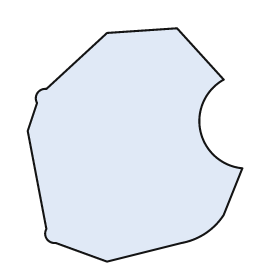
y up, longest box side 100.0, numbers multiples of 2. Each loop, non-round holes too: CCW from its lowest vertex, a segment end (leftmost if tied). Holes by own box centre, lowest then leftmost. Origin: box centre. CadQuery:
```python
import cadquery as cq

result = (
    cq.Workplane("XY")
    .moveTo(-12.0, -50.0)
    .lineTo(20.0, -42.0)
    .threePointArc((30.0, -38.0), (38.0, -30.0))
    .lineTo(46.0, -10.0)
    .threePointArc((28.0, 6.0), (38.0, 28.0))
    .lineTo(18.0, 50.0)
    .lineTo(-12.0, 48.0)
    .lineTo(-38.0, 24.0)
    .threePointArc((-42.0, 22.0), (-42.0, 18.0))
    .lineTo(-46.0, 6.0)
    .lineTo(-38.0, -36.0)
    .threePointArc((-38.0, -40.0), (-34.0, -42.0))
    .close()
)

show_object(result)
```